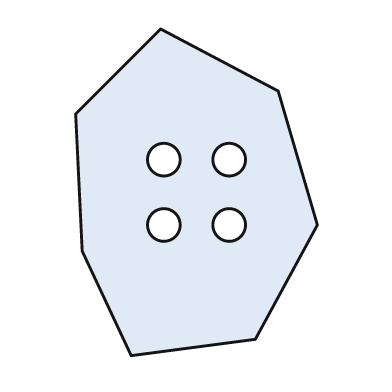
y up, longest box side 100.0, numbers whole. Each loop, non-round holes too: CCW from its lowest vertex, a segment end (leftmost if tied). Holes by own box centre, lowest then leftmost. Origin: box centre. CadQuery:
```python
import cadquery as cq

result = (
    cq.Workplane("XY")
    .moveTo(-20.0, -50.0)
    .lineTo(18.0, -45.0)
    .lineTo(37.0, -10.0)
    .lineTo(25.0, 31.0)
    .lineTo(-11.0, 50.0)
    .lineTo(-37.0, 24.0)
    .lineTo(-35.0, -18.0)
    .close()
    .moveTo(-10.0, -10.0)
    .circle(5.0)
    .moveTo(10.0, -10.0)
    .circle(5.0)
    .moveTo(-10.0, 10.0)
    .circle(5.0)
    .moveTo(10.0, 10.0)
    .circle(5.0)
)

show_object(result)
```